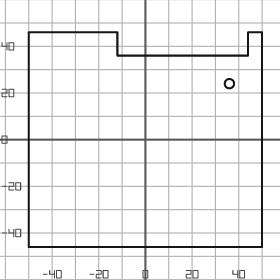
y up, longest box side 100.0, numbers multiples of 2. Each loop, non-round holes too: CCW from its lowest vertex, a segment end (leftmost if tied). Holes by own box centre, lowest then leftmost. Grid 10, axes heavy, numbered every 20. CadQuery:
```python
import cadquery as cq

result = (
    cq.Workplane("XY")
    .moveTo(-50.0, -46.0)
    .lineTo(50.0, -46.0)
    .lineTo(50.0, 46.0)
    .lineTo(44.0, 46.0)
    .lineTo(44.0, 36.0)
    .lineTo(-12.0, 36.0)
    .lineTo(-12.0, 46.0)
    .lineTo(-50.0, 46.0)
    .close()
    .moveTo(36.0, 24.0)
    .circle(2.0)
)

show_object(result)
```